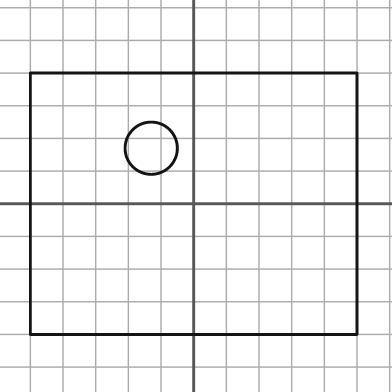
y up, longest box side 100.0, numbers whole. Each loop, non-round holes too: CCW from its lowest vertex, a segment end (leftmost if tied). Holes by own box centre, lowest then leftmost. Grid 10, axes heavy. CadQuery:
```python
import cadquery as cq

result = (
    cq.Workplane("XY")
    .moveTo(-50.0, -40.0)
    .lineTo(50.0, -40.0)
    .lineTo(50.0, 40.0)
    .lineTo(-50.0, 40.0)
    .close()
    .moveTo(-13.0, 17.0)
    .circle(8.0)
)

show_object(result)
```